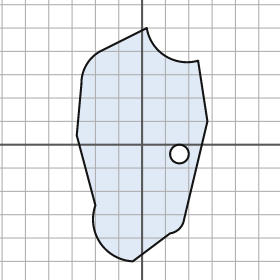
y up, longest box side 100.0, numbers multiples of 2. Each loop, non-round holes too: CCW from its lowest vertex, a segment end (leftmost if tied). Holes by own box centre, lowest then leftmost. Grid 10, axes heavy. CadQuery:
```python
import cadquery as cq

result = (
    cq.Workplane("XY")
    .moveTo(-4.0, -50.0)
    .lineTo(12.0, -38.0)
    .threePointArc((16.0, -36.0), (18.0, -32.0))
    .lineTo(28.0, 10.0)
    .lineTo(24.0, 36.0)
    .threePointArc((10.0, 38.0), (2.0, 50.0))
    .lineTo(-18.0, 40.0)
    .threePointArc((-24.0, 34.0), (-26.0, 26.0))
    .lineTo(-28.0, 4.0)
    .lineTo(-20.0, -26.0)
    .threePointArc((-18.0, -42.0), (-4.0, -50.0))
    .close()
    .moveTo(16.0, -4.0)
    .circle(4.0)
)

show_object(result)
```